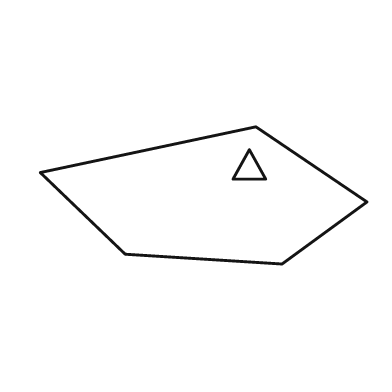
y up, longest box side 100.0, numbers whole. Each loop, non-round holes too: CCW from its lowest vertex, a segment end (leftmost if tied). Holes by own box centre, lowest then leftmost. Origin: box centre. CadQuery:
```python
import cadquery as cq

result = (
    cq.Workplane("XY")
    .moveTo(24.0, -21.0)
    .lineTo(50.0, -2.0)
    .lineTo(16.0, 21.0)
    .lineTo(-50.0, 7.0)
    .lineTo(-24.0, -18.0)
    .close()
    .moveTo(9.0, 5.0)
    .lineTo(19.0, 5.0)
    .lineTo(14.0, 14.0)
    .close()
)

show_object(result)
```